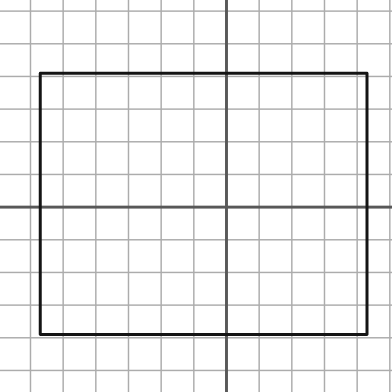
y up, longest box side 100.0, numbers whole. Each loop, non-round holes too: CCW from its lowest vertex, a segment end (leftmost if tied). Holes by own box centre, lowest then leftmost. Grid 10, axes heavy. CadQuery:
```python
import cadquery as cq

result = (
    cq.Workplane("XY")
    .moveTo(-57.0, -39.0)
    .lineTo(43.0, -39.0)
    .lineTo(43.0, 41.0)
    .lineTo(-57.0, 41.0)
    .close()
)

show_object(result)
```